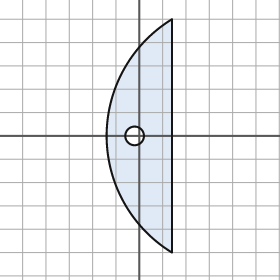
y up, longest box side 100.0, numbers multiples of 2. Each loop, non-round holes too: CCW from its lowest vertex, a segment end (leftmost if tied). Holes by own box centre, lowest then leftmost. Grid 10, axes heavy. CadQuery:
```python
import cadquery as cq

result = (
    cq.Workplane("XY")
    .moveTo(14.0, -50.0)
    .lineTo(14.0, 50.0)
    .threePointArc((-14.0, 0.0), (14.0, -50.0))
    .close()
    .moveTo(-2.0, 0.0)
    .circle(4.0)
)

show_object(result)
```